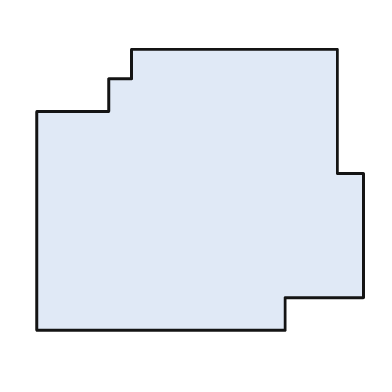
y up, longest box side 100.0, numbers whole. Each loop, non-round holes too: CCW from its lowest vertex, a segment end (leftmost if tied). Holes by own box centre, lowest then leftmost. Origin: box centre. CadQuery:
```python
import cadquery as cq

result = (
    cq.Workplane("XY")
    .moveTo(-50.0, -43.0)
    .lineTo(26.0, -43.0)
    .lineTo(26.0, -33.0)
    .lineTo(50.0, -33.0)
    .lineTo(50.0, 5.0)
    .lineTo(42.0, 5.0)
    .lineTo(42.0, 43.0)
    .lineTo(-21.0, 43.0)
    .lineTo(-21.0, 34.0)
    .lineTo(-28.0, 34.0)
    .lineTo(-28.0, 24.0)
    .lineTo(-50.0, 24.0)
    .close()
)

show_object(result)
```